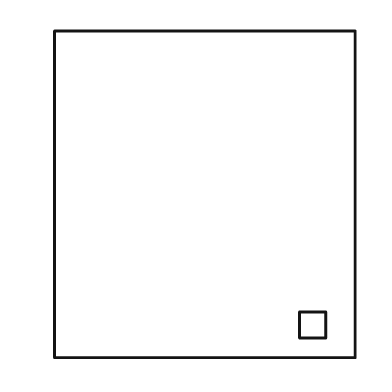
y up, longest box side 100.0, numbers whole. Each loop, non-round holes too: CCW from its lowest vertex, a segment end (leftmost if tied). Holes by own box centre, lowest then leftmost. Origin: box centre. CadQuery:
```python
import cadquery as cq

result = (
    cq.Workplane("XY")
    .moveTo(-46.0, -50.0)
    .lineTo(46.0, -50.0)
    .lineTo(46.0, 50.0)
    .lineTo(-46.0, 50.0)
    .close()
    .moveTo(29.0, -44.0)
    .lineTo(37.0, -44.0)
    .lineTo(37.0, -36.0)
    .lineTo(29.0, -36.0)
    .close()
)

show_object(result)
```